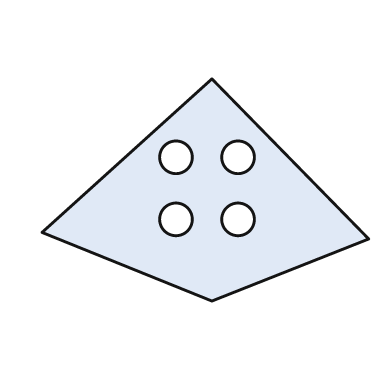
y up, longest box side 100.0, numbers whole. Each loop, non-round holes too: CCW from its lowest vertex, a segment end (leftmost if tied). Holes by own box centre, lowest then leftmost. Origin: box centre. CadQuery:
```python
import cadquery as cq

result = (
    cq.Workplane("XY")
    .moveTo(2.0, -34.0)
    .lineTo(50.0, -15.0)
    .lineTo(2.0, 34.0)
    .lineTo(-50.0, -13.0)
    .close()
    .moveTo(-9.0, -9.0)
    .circle(5.0)
    .moveTo(10.0, -9.0)
    .circle(5.0)
    .moveTo(-9.0, 10.0)
    .circle(5.0)
    .moveTo(10.0, 10.0)
    .circle(5.0)
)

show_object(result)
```